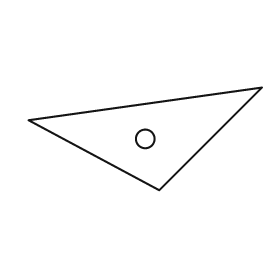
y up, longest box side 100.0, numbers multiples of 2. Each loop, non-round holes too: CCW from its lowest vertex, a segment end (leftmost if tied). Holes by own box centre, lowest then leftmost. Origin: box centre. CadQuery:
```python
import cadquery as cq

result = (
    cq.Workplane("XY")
    .moveTo(6.0, -22.0)
    .lineTo(50.0, 22.0)
    .lineTo(-50.0, 8.0)
    .close()
    .moveTo(0.0, 0.0)
    .circle(4.0)
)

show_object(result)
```